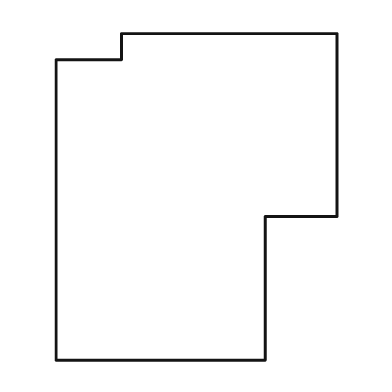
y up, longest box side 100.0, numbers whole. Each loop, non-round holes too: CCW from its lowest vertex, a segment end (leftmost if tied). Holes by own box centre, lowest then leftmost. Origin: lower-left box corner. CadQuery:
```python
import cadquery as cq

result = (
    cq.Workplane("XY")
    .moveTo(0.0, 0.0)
    .lineTo(64.0, 0.0)
    .lineTo(64.0, 44.0)
    .lineTo(86.0, 44.0)
    .lineTo(86.0, 100.0)
    .lineTo(20.0, 100.0)
    .lineTo(20.0, 92.0)
    .lineTo(0.0, 92.0)
    .close()
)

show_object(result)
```